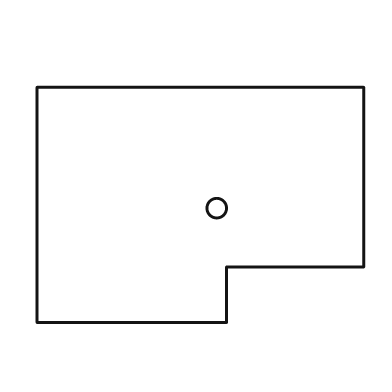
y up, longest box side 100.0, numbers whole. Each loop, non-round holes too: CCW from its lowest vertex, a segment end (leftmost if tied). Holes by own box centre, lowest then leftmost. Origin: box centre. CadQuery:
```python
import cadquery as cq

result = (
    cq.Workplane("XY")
    .moveTo(-50.0, -36.0)
    .lineTo(8.0, -36.0)
    .lineTo(8.0, -19.0)
    .lineTo(50.0, -19.0)
    .lineTo(50.0, 36.0)
    .lineTo(-50.0, 36.0)
    .close()
    .moveTo(5.0, -1.0)
    .circle(3.0)
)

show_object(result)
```